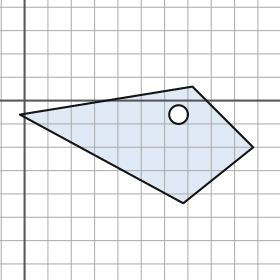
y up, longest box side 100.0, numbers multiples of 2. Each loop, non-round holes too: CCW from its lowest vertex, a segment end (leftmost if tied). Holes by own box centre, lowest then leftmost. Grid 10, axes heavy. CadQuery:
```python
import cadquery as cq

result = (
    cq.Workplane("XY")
    .moveTo(68.0, -44.0)
    .lineTo(98.0, -20.0)
    .lineTo(72.0, 6.0)
    .lineTo(-2.0, -6.0)
    .close()
    .moveTo(66.0, -6.0)
    .circle(4.0)
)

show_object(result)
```